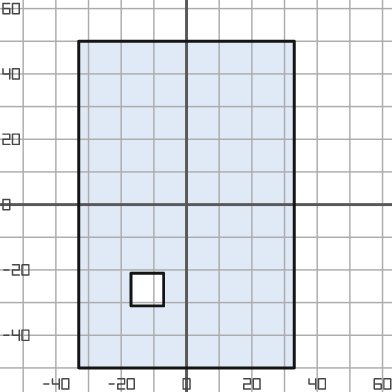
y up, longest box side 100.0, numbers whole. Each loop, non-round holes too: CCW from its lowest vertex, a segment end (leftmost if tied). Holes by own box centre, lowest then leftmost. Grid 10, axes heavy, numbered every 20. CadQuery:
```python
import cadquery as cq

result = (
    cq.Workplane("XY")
    .moveTo(-33.0, -50.0)
    .lineTo(33.0, -50.0)
    .lineTo(33.0, 50.0)
    .lineTo(-33.0, 50.0)
    .close()
    .moveTo(-17.0, -31.0)
    .lineTo(-7.0, -31.0)
    .lineTo(-7.0, -21.0)
    .lineTo(-17.0, -21.0)
    .close()
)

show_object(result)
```